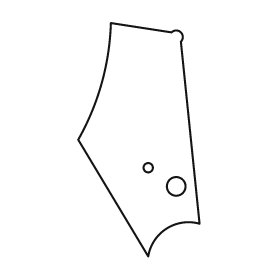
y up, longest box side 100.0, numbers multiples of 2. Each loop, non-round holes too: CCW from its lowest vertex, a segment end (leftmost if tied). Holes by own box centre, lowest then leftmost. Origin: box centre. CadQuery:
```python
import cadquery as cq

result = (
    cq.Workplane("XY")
    .moveTo(4.0, -50.0)
    .threePointArc((12.0, -38.0), (26.0, -36.0))
    .lineTo(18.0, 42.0)
    .threePointArc((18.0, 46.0), (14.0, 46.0))
    .lineTo(-12.0, 50.0)
    .threePointArc((-16.0, 24.0), (-26.0, 0.0))
    .close()
    .moveTo(16.0, -20.0)
    .circle(4.0)
    .moveTo(4.0, -12.0)
    .circle(2.0)
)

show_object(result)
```